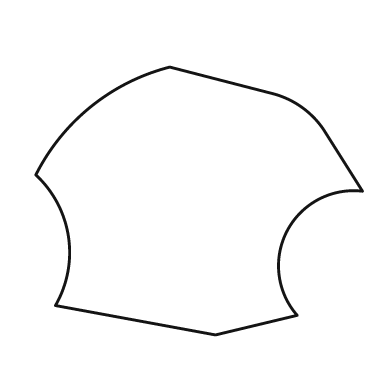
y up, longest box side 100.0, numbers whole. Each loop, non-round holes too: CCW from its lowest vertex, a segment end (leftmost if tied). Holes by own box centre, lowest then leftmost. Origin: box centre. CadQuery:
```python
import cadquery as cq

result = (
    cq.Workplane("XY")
    .moveTo(5.0, -41.0)
    .lineTo(30.0, -35.0)
    .threePointArc((27.0, -9.0), (50.0, 3.0))
    .lineTo(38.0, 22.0)
    .threePointArc((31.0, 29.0), (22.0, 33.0))
    .lineTo(-9.0, 41.0)
    .threePointArc((-33.0, 29.0), (-50.0, 8.0))
    .threePointArc((-40.0, -11.0), (-44.0, -32.0))
    .close()
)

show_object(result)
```